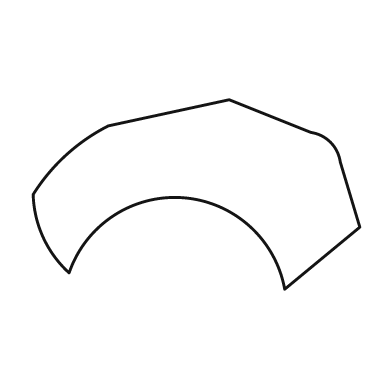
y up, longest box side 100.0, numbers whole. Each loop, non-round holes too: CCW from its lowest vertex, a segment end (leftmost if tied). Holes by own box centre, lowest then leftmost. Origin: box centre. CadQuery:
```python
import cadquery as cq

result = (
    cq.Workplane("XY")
    .moveTo(27.0, -29.0)
    .lineTo(50.0, -10.0)
    .lineTo(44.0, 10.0)
    .threePointArc((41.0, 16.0), (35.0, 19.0))
    .lineTo(10.0, 29.0)
    .lineTo(-27.0, 21.0)
    .threePointArc((-40.0, 12.0), (-50.0, 0.0))
    .threePointArc((-47.0, -13.0), (-39.0, -24.0))
    .threePointArc((-4.0, -1.0), (27.0, -29.0))
    .close()
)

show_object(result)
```